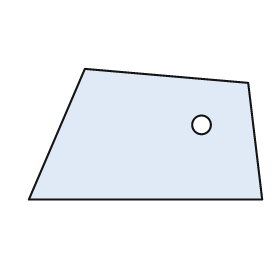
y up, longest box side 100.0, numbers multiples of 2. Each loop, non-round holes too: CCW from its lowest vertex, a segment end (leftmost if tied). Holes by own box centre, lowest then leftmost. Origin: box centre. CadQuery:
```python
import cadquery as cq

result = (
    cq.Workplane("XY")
    .moveTo(-50.0, -28.0)
    .lineTo(50.0, -28.0)
    .lineTo(44.0, 22.0)
    .lineTo(-26.0, 28.0)
    .close()
    .moveTo(24.0, 4.0)
    .circle(4.0)
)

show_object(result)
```